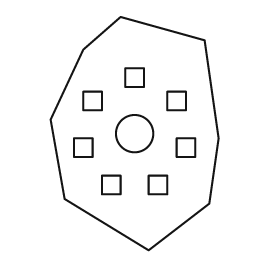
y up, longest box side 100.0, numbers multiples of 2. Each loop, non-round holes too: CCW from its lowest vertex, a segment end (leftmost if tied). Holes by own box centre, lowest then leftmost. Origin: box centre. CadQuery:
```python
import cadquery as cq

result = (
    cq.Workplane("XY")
    .moveTo(6.0, -50.0)
    .lineTo(32.0, -30.0)
    .lineTo(36.0, -2.0)
    .lineTo(30.0, 40.0)
    .lineTo(-6.0, 50.0)
    .lineTo(-22.0, 36.0)
    .lineTo(-36.0, 6.0)
    .lineTo(-30.0, -28.0)
    .close()
    .moveTo(-14.0, -26.0)
    .lineTo(-6.0, -26.0)
    .lineTo(-6.0, -18.0)
    .lineTo(-14.0, -18.0)
    .close()
    .moveTo(6.0, -26.0)
    .lineTo(14.0, -26.0)
    .lineTo(14.0, -18.0)
    .lineTo(6.0, -18.0)
    .close()
    .moveTo(-26.0, -10.0)
    .lineTo(-18.0, -10.0)
    .lineTo(-18.0, -2.0)
    .lineTo(-26.0, -2.0)
    .close()
    .moveTo(18.0, -10.0)
    .lineTo(26.0, -10.0)
    .lineTo(26.0, -2.0)
    .lineTo(18.0, -2.0)
    .close()
    .moveTo(0.0, 0.0)
    .circle(8.0)
    .moveTo(-22.0, 10.0)
    .lineTo(-14.0, 10.0)
    .lineTo(-14.0, 18.0)
    .lineTo(-22.0, 18.0)
    .close()
    .moveTo(14.0, 10.0)
    .lineTo(22.0, 10.0)
    .lineTo(22.0, 18.0)
    .lineTo(14.0, 18.0)
    .close()
    .moveTo(-4.0, 20.0)
    .lineTo(4.0, 20.0)
    .lineTo(4.0, 28.0)
    .lineTo(-4.0, 28.0)
    .close()
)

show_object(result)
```